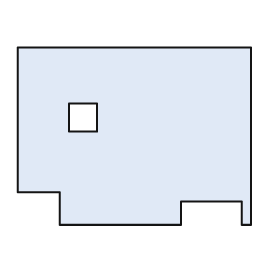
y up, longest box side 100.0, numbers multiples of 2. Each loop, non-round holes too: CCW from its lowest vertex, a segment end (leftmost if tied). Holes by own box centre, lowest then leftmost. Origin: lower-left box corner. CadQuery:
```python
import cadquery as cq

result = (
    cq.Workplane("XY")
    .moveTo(18.0, 0.0)
    .lineTo(70.0, 0.0)
    .lineTo(70.0, 10.0)
    .lineTo(96.0, 10.0)
    .lineTo(96.0, 0.0)
    .lineTo(100.0, 0.0)
    .lineTo(100.0, 76.0)
    .lineTo(0.0, 76.0)
    .lineTo(0.0, 14.0)
    .lineTo(18.0, 14.0)
    .close()
    .moveTo(22.0, 40.0)
    .lineTo(34.0, 40.0)
    .lineTo(34.0, 52.0)
    .lineTo(22.0, 52.0)
    .close()
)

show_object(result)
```